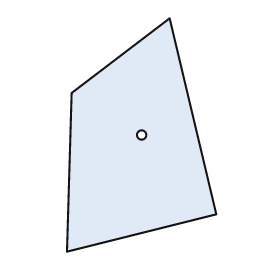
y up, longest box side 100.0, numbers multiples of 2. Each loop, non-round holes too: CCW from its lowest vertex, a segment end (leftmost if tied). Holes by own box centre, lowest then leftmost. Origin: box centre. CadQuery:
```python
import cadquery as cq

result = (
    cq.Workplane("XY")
    .moveTo(-32.0, -50.0)
    .lineTo(32.0, -34.0)
    .lineTo(12.0, 50.0)
    .lineTo(-30.0, 18.0)
    .close()
    .moveTo(0.0, 0.0)
    .circle(2.0)
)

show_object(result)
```